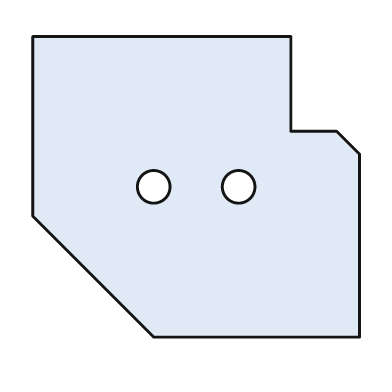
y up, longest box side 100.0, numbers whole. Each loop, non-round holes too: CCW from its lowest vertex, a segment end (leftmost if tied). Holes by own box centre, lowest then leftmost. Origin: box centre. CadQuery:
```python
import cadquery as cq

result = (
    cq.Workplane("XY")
    .moveTo(-13.0, -46.0)
    .lineTo(50.0, -46.0)
    .lineTo(50.0, 10.0)
    .lineTo(43.0, 17.0)
    .lineTo(29.0, 17.0)
    .lineTo(29.0, 46.0)
    .lineTo(-50.0, 46.0)
    .lineTo(-50.0, -9.0)
    .close()
    .moveTo(-13.0, 0.0)
    .circle(5.0)
    .moveTo(13.0, 0.0)
    .circle(5.0)
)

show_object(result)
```